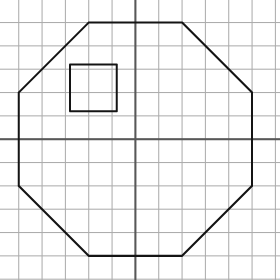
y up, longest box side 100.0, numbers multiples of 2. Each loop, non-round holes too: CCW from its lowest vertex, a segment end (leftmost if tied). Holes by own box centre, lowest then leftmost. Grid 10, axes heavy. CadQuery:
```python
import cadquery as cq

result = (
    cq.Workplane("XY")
    .moveTo(-20.0, -50.0)
    .lineTo(20.0, -50.0)
    .lineTo(50.0, -20.0)
    .lineTo(50.0, 20.0)
    .lineTo(20.0, 50.0)
    .lineTo(-20.0, 50.0)
    .lineTo(-50.0, 20.0)
    .lineTo(-50.0, -20.0)
    .close()
    .moveTo(-28.0, 12.0)
    .lineTo(-8.0, 12.0)
    .lineTo(-8.0, 32.0)
    .lineTo(-28.0, 32.0)
    .close()
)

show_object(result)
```